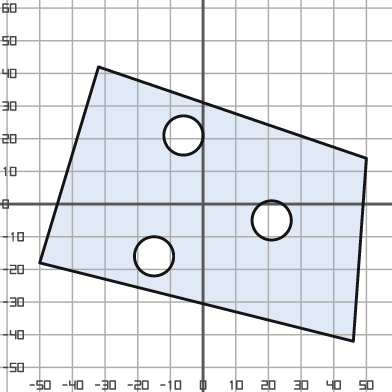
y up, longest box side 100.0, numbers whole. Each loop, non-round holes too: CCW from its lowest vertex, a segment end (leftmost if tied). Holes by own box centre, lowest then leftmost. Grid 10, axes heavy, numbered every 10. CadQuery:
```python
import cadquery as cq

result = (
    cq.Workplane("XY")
    .moveTo(46.0, -42.0)
    .lineTo(50.0, 14.0)
    .lineTo(-32.0, 42.0)
    .lineTo(-50.0, -18.0)
    .close()
    .moveTo(-15.0, -16.0)
    .circle(6.0)
    .moveTo(21.0, -5.0)
    .circle(6.0)
    .moveTo(-6.0, 21.0)
    .circle(6.0)
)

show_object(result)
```